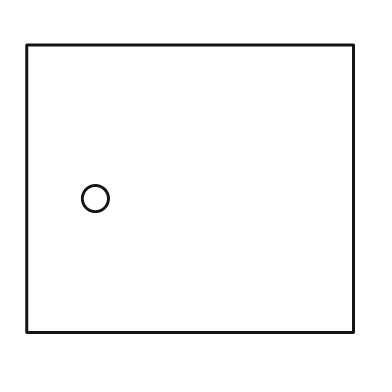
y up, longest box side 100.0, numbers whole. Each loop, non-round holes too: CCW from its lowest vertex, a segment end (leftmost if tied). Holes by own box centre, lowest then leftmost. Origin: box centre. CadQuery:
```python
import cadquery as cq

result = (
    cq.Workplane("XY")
    .moveTo(-50.0, -44.0)
    .lineTo(50.0, -44.0)
    .lineTo(50.0, 44.0)
    .lineTo(-50.0, 44.0)
    .close()
    .moveTo(-29.0, -3.0)
    .circle(4.0)
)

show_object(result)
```